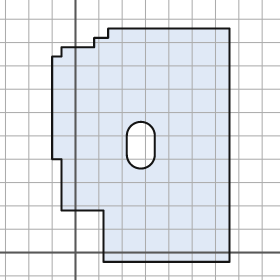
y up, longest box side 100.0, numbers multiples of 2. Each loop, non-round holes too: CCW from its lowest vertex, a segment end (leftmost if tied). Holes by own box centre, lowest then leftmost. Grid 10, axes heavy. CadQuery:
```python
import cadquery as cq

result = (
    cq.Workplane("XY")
    .moveTo(12.0, -4.0)
    .lineTo(66.0, -4.0)
    .lineTo(66.0, 96.0)
    .lineTo(14.0, 96.0)
    .lineTo(14.0, 92.0)
    .lineTo(8.0, 92.0)
    .lineTo(8.0, 88.0)
    .lineTo(-6.0, 88.0)
    .lineTo(-6.0, 84.0)
    .lineTo(-10.0, 84.0)
    .lineTo(-10.0, 40.0)
    .lineTo(-6.0, 40.0)
    .lineTo(-6.0, 18.0)
    .lineTo(12.0, 18.0)
    .close()
    .moveTo(22.0, 42.0)
    .threePointArc((28.0, 36.0), (34.0, 42.0))
    .lineTo(34.0, 50.0)
    .threePointArc((28.0, 56.0), (22.0, 50.0))
    .close()
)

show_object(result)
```